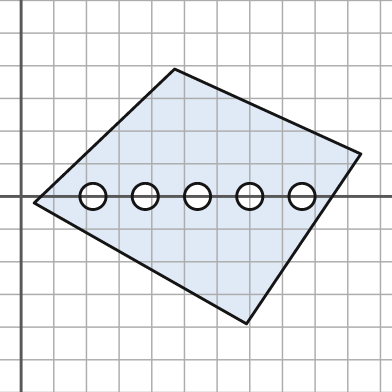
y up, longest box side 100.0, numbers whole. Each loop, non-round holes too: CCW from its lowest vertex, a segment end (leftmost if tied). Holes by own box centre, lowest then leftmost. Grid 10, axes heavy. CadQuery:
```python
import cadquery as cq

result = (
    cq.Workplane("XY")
    .moveTo(69.0, -39.0)
    .lineTo(104.0, 13.0)
    .lineTo(47.0, 39.0)
    .lineTo(4.0, -2.0)
    .close()
    .moveTo(22.0, 0.0)
    .circle(4.0)
    .moveTo(38.0, 0.0)
    .circle(4.0)
    .moveTo(54.0, 0.0)
    .circle(4.0)
    .moveTo(70.0, 0.0)
    .circle(4.0)
    .moveTo(86.0, 0.0)
    .circle(4.0)
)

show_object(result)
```